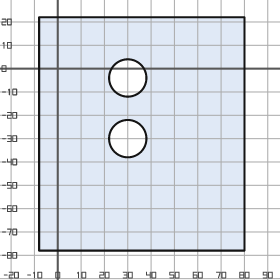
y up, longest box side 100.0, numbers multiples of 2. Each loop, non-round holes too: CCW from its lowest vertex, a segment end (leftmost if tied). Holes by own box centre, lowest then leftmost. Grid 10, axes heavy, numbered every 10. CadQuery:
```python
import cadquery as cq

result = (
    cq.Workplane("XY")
    .moveTo(-8.0, -78.0)
    .lineTo(80.0, -78.0)
    .lineTo(80.0, 22.0)
    .lineTo(-8.0, 22.0)
    .close()
    .moveTo(30.0, -30.0)
    .circle(8.0)
    .moveTo(30.0, -4.0)
    .circle(8.0)
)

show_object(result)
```